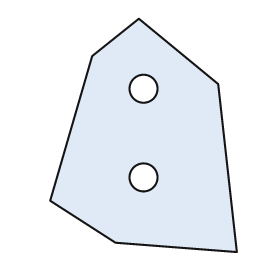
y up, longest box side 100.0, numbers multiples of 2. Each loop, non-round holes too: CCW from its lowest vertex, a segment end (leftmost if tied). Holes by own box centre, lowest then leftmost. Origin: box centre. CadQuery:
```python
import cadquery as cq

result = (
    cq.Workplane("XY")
    .moveTo(40.0, -50.0)
    .lineTo(32.0, 22.0)
    .lineTo(-2.0, 50.0)
    .lineTo(-22.0, 34.0)
    .lineTo(-40.0, -28.0)
    .lineTo(-12.0, -46.0)
    .close()
    .moveTo(0.0, -18.0)
    .circle(6.0)
    .moveTo(0.0, 20.0)
    .circle(6.0)
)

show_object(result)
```